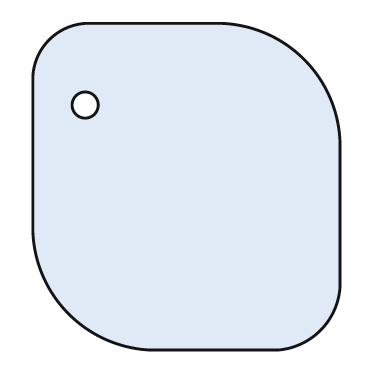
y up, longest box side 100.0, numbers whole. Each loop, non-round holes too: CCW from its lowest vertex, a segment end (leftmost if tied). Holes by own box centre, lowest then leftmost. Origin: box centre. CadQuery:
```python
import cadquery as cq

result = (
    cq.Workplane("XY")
    .moveTo(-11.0, -50.0)
    .lineTo(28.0, -50.0)
    .threePointArc((41.0, -44.0), (47.0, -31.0))
    .lineTo(47.0, 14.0)
    .threePointArc((36.0, 39.0), (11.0, 50.0))
    .lineTo(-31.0, 50.0)
    .threePointArc((-42.0, 45.0), (-47.0, 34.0))
    .lineTo(-47.0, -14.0)
    .threePointArc((-36.0, -39.0), (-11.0, -50.0))
    .close()
    .moveTo(-31.0, 25.0)
    .circle(4.0)
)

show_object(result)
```